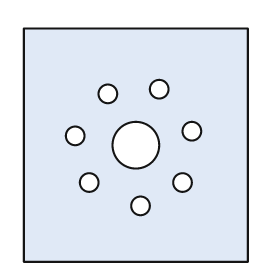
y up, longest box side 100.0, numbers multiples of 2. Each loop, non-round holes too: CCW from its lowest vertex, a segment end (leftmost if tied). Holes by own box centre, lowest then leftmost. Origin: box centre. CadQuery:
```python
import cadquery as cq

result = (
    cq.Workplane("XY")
    .moveTo(-48.0, -50.0)
    .lineTo(48.0, -50.0)
    .lineTo(48.0, 50.0)
    .lineTo(-48.0, 50.0)
    .close()
    .moveTo(2.0, -26.0)
    .circle(4.0)
    .moveTo(-20.0, -16.0)
    .circle(4.0)
    .moveTo(20.0, -16.0)
    .circle(4.0)
    .moveTo(0.0, 0.0)
    .circle(10.0)
    .moveTo(-26.0, 4.0)
    .circle(4.0)
    .moveTo(24.0, 6.0)
    .circle(4.0)
    .moveTo(-12.0, 22.0)
    .circle(4.0)
    .moveTo(10.0, 24.0)
    .circle(4.0)
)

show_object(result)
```